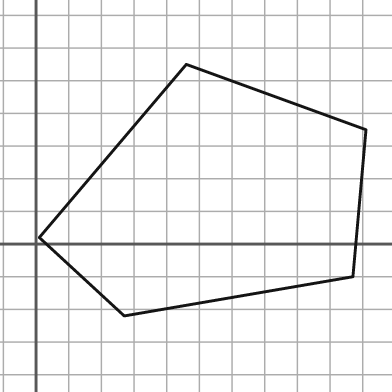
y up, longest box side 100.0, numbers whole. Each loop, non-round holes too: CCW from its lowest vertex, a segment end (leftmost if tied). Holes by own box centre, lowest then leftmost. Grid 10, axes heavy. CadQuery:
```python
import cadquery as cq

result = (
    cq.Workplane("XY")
    .moveTo(27.0, -22.0)
    .lineTo(97.0, -10.0)
    .lineTo(101.0, 35.0)
    .lineTo(46.0, 55.0)
    .lineTo(1.0, 2.0)
    .close()
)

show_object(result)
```